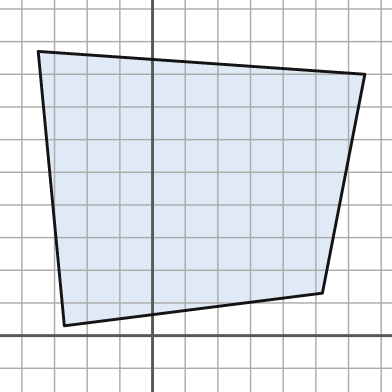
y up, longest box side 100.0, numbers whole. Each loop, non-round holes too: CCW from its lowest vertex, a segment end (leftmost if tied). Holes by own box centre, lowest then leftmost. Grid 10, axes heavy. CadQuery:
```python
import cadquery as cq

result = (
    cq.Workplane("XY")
    .moveTo(-27.0, 3.0)
    .lineTo(52.0, 13.0)
    .lineTo(65.0, 80.0)
    .lineTo(-35.0, 87.0)
    .close()
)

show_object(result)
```